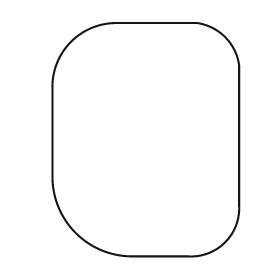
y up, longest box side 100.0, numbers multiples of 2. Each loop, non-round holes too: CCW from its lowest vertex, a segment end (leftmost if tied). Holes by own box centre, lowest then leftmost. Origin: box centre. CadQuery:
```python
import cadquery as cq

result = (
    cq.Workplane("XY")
    .moveTo(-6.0, -50.0)
    .lineTo(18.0, -50.0)
    .threePointArc((34.0, -44.0), (40.0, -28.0))
    .lineTo(40.0, 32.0)
    .threePointArc((34.0, 44.0), (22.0, 50.0))
    .lineTo(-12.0, 50.0)
    .threePointArc((-32.0, 42.0), (-40.0, 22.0))
    .lineTo(-40.0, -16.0)
    .threePointArc((-30.0, -40.0), (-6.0, -50.0))
    .close()
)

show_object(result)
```